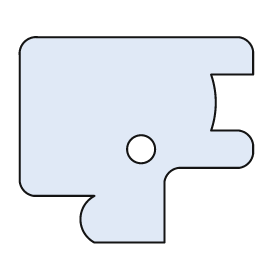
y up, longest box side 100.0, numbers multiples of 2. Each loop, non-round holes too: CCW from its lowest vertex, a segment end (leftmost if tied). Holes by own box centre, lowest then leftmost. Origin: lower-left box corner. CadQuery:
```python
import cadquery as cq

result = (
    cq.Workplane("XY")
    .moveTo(32.0, 0.0)
    .lineTo(62.0, 0.0)
    .lineTo(62.0, 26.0)
    .threePointArc((64.0, 30.0), (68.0, 32.0))
    .lineTo(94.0, 32.0)
    .threePointArc((98.0, 34.0), (100.0, 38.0))
    .lineTo(100.0, 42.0)
    .threePointArc((98.0, 46.0), (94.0, 48.0))
    .lineTo(82.0, 48.0)
    .threePointArc((84.0, 60.0), (82.0, 72.0))
    .lineTo(100.0, 72.0)
    .lineTo(100.0, 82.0)
    .threePointArc((98.0, 86.0), (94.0, 88.0))
    .lineTo(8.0, 88.0)
    .threePointArc((2.0, 86.0), (0.0, 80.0))
    .lineTo(0.0, 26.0)
    .threePointArc((2.0, 22.0), (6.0, 20.0))
    .lineTo(32.0, 20.0)
    .threePointArc((26.0, 10.0), (32.0, 0.0))
    .close()
    .moveTo(52.0, 40.0)
    .circle(6.0)
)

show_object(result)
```